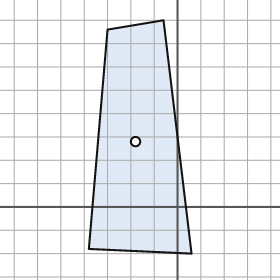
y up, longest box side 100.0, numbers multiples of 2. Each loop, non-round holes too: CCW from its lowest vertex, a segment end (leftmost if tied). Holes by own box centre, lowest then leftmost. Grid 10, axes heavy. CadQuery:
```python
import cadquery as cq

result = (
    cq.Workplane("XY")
    .moveTo(6.0, -20.0)
    .lineTo(-6.0, 80.0)
    .lineTo(-30.0, 76.0)
    .lineTo(-38.0, -18.0)
    .close()
    .moveTo(-18.0, 28.0)
    .circle(2.0)
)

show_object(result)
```